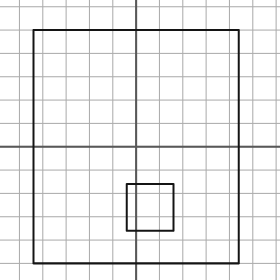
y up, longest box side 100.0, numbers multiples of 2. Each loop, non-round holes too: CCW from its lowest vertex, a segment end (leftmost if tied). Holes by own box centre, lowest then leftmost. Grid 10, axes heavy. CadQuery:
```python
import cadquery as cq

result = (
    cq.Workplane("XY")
    .moveTo(-44.0, -50.0)
    .lineTo(44.0, -50.0)
    .lineTo(44.0, 50.0)
    .lineTo(-44.0, 50.0)
    .close()
    .moveTo(-4.0, -36.0)
    .lineTo(16.0, -36.0)
    .lineTo(16.0, -16.0)
    .lineTo(-4.0, -16.0)
    .close()
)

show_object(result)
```